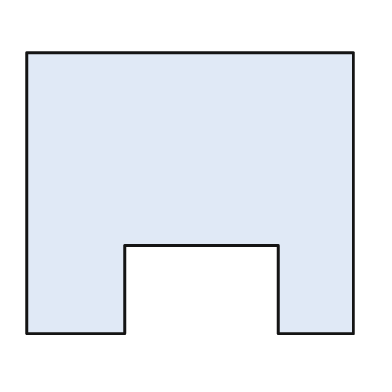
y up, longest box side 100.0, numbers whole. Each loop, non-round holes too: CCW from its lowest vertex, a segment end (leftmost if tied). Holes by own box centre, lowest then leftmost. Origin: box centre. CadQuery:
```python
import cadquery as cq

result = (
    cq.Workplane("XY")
    .moveTo(-50.0, -43.0)
    .lineTo(-20.0, -43.0)
    .lineTo(-20.0, -16.0)
    .lineTo(27.0, -16.0)
    .lineTo(27.0, -43.0)
    .lineTo(50.0, -43.0)
    .lineTo(50.0, 43.0)
    .lineTo(-50.0, 43.0)
    .close()
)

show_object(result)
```